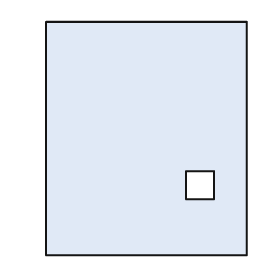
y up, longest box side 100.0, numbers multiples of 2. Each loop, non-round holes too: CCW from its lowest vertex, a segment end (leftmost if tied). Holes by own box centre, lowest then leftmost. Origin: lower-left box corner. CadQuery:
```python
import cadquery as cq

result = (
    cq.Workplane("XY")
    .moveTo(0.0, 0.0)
    .lineTo(86.0, 0.0)
    .lineTo(86.0, 100.0)
    .lineTo(0.0, 100.0)
    .close()
    .moveTo(60.0, 24.0)
    .lineTo(72.0, 24.0)
    .lineTo(72.0, 36.0)
    .lineTo(60.0, 36.0)
    .close()
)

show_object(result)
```